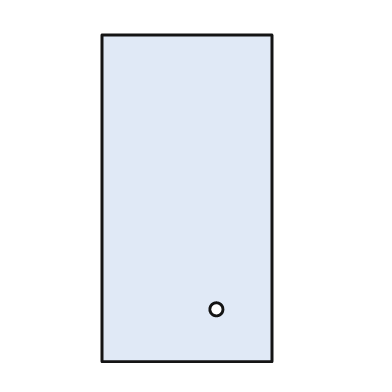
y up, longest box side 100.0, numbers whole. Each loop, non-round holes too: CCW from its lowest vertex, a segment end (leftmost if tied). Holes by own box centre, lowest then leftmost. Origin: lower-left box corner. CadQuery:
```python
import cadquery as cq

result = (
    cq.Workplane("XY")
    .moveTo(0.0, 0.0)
    .lineTo(52.0, 0.0)
    .lineTo(52.0, 100.0)
    .lineTo(0.0, 100.0)
    .close()
    .moveTo(35.0, 16.0)
    .circle(2.0)
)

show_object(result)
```